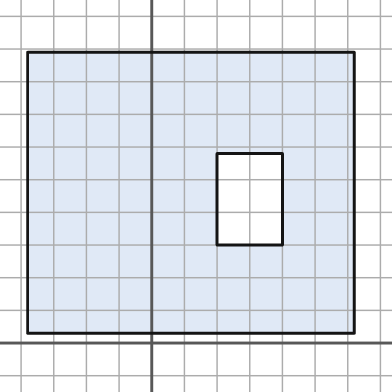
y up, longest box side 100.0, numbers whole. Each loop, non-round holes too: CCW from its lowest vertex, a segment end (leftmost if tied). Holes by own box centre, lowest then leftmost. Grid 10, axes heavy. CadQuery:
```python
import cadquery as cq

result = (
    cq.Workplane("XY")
    .moveTo(-38.0, 3.0)
    .lineTo(62.0, 3.0)
    .lineTo(62.0, 89.0)
    .lineTo(-38.0, 89.0)
    .close()
    .moveTo(20.0, 30.0)
    .lineTo(40.0, 30.0)
    .lineTo(40.0, 58.0)
    .lineTo(20.0, 58.0)
    .close()
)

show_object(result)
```